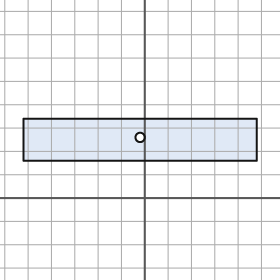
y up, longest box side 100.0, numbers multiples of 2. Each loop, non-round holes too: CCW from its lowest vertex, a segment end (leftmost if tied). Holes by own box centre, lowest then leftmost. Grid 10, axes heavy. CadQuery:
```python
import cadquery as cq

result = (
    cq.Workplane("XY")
    .moveTo(-52.0, 16.0)
    .lineTo(48.0, 16.0)
    .lineTo(48.0, 34.0)
    .lineTo(-52.0, 34.0)
    .close()
    .moveTo(-2.0, 26.0)
    .circle(2.0)
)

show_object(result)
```